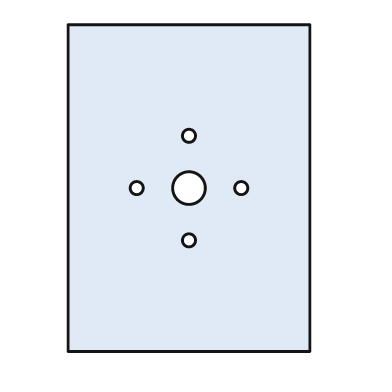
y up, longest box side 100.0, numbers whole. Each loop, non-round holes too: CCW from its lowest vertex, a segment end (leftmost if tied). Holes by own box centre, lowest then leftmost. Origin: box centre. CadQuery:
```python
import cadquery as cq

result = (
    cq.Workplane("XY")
    .moveTo(-37.0, -50.0)
    .lineTo(37.0, -50.0)
    .lineTo(37.0, 50.0)
    .lineTo(-37.0, 50.0)
    .close()
    .moveTo(0.0, -16.0)
    .circle(2.0)
    .moveTo(-16.0, 0.0)
    .circle(2.0)
    .moveTo(0.0, 0.0)
    .circle(5.0)
    .moveTo(16.0, 0.0)
    .circle(2.0)
    .moveTo(0.0, 16.0)
    .circle(2.0)
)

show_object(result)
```